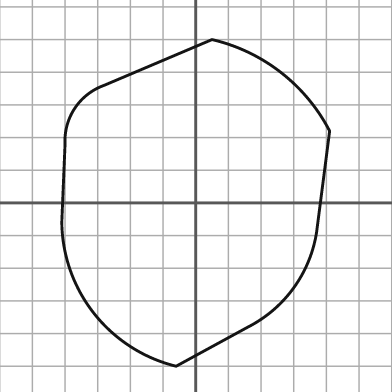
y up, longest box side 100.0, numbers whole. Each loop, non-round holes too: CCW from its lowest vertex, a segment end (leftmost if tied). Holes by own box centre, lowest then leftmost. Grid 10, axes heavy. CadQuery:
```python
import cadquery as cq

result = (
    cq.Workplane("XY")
    .moveTo(-6.0, -50.0)
    .lineTo(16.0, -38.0)
    .threePointArc((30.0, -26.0), (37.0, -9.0))
    .lineTo(41.0, 22.0)
    .threePointArc((26.0, 40.0), (5.0, 50.0))
    .lineTo(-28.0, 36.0)
    .threePointArc((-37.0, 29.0), (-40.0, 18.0))
    .lineTo(-41.0, -6.0)
    .threePointArc((-31.0, -34.0), (-6.0, -50.0))
    .close()
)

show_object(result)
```